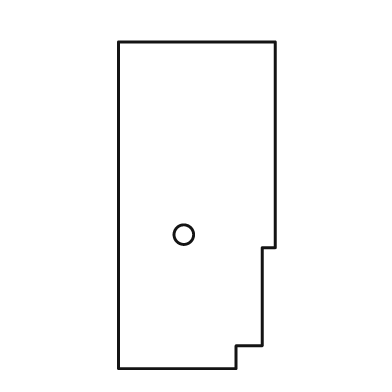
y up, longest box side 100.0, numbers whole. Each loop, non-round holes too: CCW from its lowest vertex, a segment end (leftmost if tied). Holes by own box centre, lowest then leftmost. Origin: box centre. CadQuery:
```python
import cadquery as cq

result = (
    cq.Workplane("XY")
    .moveTo(-24.0, -50.0)
    .lineTo(12.0, -50.0)
    .lineTo(12.0, -43.0)
    .lineTo(20.0, -43.0)
    .lineTo(20.0, -13.0)
    .lineTo(24.0, -13.0)
    .lineTo(24.0, 50.0)
    .lineTo(-24.0, 50.0)
    .close()
    .moveTo(-4.0, -9.0)
    .circle(3.0)
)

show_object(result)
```